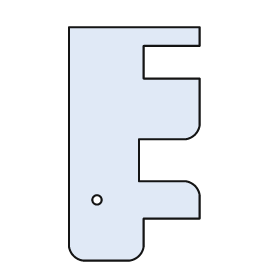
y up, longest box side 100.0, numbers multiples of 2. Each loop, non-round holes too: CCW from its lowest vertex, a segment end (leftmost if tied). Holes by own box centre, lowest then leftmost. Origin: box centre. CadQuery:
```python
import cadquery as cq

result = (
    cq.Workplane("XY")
    .moveTo(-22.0, -50.0)
    .lineTo(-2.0, -50.0)
    .threePointArc((2.0, -48.0), (4.0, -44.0))
    .lineTo(4.0, -32.0)
    .lineTo(28.0, -32.0)
    .lineTo(28.0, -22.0)
    .threePointArc((26.0, -18.0), (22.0, -16.0))
    .lineTo(2.0, -16.0)
    .lineTo(2.0, 2.0)
    .lineTo(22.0, 2.0)
    .threePointArc((26.0, 4.0), (28.0, 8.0))
    .lineTo(28.0, 28.0)
    .lineTo(4.0, 28.0)
    .lineTo(4.0, 42.0)
    .lineTo(28.0, 42.0)
    .lineTo(28.0, 50.0)
    .lineTo(-28.0, 50.0)
    .lineTo(-28.0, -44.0)
    .threePointArc((-26.0, -48.0), (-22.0, -50.0))
    .close()
    .moveTo(-16.0, -24.0)
    .circle(2.0)
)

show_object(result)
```